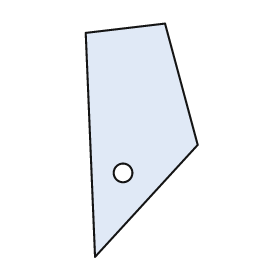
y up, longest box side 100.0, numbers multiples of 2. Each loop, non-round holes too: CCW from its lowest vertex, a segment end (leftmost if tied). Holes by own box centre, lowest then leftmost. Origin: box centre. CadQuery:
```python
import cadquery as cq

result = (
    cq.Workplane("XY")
    .moveTo(-20.0, -50.0)
    .lineTo(24.0, -2.0)
    .lineTo(10.0, 50.0)
    .lineTo(-24.0, 46.0)
    .close()
    .moveTo(-8.0, -14.0)
    .circle(4.0)
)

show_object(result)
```